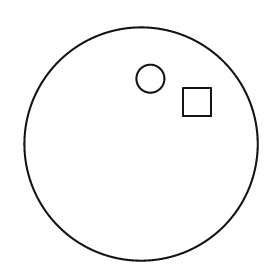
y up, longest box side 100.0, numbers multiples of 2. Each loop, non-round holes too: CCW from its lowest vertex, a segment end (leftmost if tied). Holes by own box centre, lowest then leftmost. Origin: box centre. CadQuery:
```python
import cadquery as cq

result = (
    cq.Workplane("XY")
    .moveTo(0.0, 0.0)
    .circle(50.0)
    .moveTo(18.0, 12.0)
    .lineTo(30.0, 12.0)
    .lineTo(30.0, 24.0)
    .lineTo(18.0, 24.0)
    .close()
    .moveTo(4.0, 28.0)
    .circle(6.0)
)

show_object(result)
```